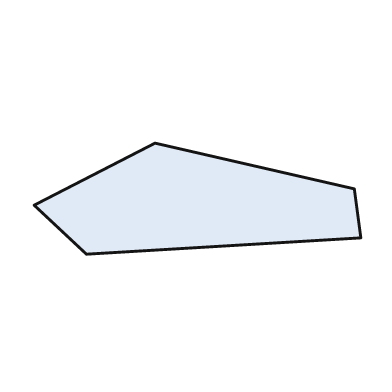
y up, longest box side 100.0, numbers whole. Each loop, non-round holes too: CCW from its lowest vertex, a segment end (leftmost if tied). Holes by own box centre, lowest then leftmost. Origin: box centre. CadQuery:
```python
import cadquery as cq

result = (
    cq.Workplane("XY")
    .moveTo(-34.0, -17.0)
    .lineTo(50.0, -12.0)
    .lineTo(48.0, 3.0)
    .lineTo(-13.0, 17.0)
    .lineTo(-50.0, -2.0)
    .close()
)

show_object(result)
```